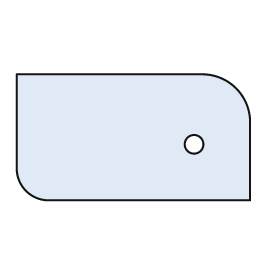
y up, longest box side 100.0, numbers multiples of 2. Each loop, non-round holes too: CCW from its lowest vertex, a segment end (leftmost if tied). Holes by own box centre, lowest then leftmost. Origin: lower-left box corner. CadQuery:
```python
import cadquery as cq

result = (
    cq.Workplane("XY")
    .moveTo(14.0, 0.0)
    .lineTo(100.0, 0.0)
    .lineTo(100.0, 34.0)
    .threePointArc((94.0, 48.0), (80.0, 54.0))
    .lineTo(0.0, 54.0)
    .lineTo(0.0, 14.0)
    .threePointArc((4.0, 4.0), (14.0, 0.0))
    .close()
    .moveTo(76.0, 24.0)
    .circle(4.0)
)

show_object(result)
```